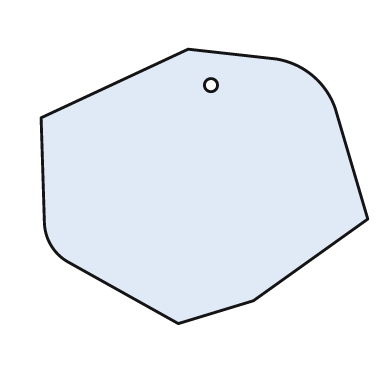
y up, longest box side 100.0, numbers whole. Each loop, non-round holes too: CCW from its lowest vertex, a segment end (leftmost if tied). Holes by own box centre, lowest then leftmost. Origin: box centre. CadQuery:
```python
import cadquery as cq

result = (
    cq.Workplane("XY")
    .moveTo(-8.0, -42.0)
    .lineTo(15.0, -35.0)
    .lineTo(50.0, -10.0)
    .lineTo(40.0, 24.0)
    .threePointArc((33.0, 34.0), (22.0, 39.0))
    .lineTo(-5.0, 42.0)
    .lineTo(-50.0, 21.0)
    .lineTo(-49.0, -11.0)
    .threePointArc((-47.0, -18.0), (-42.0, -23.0))
    .close()
    .moveTo(2.0, 31.0)
    .circle(2.0)
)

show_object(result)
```